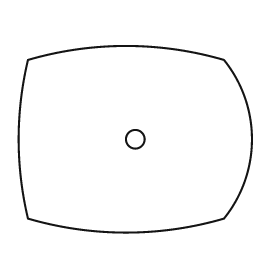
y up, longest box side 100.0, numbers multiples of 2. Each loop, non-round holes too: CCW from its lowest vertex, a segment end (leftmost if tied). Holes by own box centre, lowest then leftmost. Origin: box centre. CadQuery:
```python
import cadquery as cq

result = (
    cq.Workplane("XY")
    .moveTo(-46.0, -34.0)
    .threePointArc((-4.0, -40.0), (38.0, -34.0))
    .threePointArc((50.0, 0.0), (38.0, 34.0))
    .threePointArc((-4.0, 40.0), (-46.0, 34.0))
    .threePointArc((-50.0, 0.0), (-46.0, -34.0))
    .close()
    .moveTo(0.0, 0.0)
    .circle(4.0)
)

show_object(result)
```